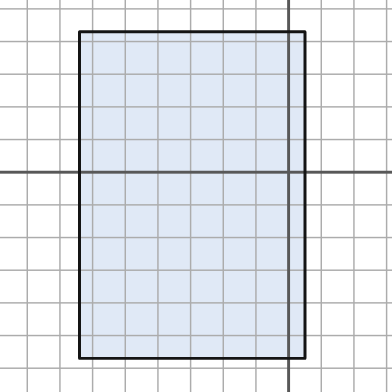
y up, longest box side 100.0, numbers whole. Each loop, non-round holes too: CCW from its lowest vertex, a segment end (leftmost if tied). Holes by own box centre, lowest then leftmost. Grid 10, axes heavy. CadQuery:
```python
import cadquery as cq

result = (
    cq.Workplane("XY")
    .moveTo(-64.0, -57.0)
    .lineTo(5.0, -57.0)
    .lineTo(5.0, 43.0)
    .lineTo(-64.0, 43.0)
    .close()
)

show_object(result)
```